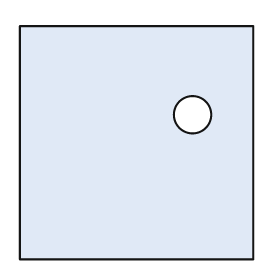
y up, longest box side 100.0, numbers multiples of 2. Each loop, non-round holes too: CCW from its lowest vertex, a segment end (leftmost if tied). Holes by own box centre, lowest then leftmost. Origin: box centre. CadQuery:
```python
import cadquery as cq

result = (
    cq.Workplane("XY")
    .moveTo(-50.0, -50.0)
    .lineTo(50.0, -50.0)
    .lineTo(50.0, 50.0)
    .lineTo(-50.0, 50.0)
    .close()
    .moveTo(24.0, 12.0)
    .circle(8.0)
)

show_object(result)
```